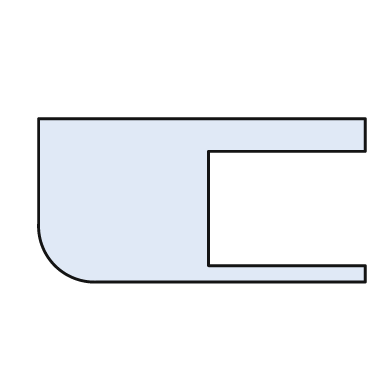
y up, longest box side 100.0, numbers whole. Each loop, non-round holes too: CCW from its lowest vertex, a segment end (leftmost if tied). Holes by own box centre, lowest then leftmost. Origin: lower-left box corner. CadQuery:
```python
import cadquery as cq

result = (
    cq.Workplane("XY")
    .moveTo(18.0, 0.0)
    .lineTo(100.0, 0.0)
    .lineTo(100.0, 5.0)
    .lineTo(52.0, 5.0)
    .lineTo(52.0, 40.0)
    .lineTo(100.0, 40.0)
    .lineTo(100.0, 50.0)
    .lineTo(0.0, 50.0)
    .lineTo(0.0, 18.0)
    .threePointArc((5.0, 5.0), (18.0, 0.0))
    .close()
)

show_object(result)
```